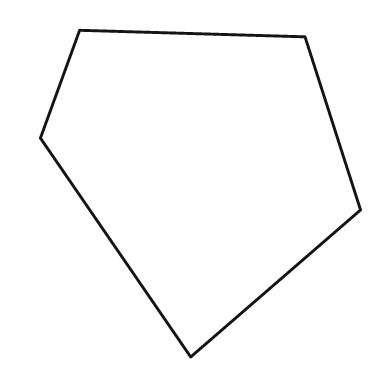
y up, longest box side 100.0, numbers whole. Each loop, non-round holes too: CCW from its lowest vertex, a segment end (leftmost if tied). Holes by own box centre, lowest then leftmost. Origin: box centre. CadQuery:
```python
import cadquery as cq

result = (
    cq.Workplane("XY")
    .moveTo(-3.0, -50.0)
    .lineTo(49.0, -5.0)
    .lineTo(32.0, 48.0)
    .lineTo(-37.0, 50.0)
    .lineTo(-49.0, 17.0)
    .close()
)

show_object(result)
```